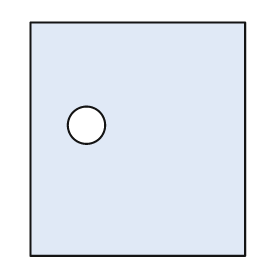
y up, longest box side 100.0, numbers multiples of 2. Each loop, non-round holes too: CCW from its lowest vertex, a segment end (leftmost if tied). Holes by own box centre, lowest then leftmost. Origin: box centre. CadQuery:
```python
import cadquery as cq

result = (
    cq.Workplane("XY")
    .moveTo(-46.0, -50.0)
    .lineTo(46.0, -50.0)
    .lineTo(46.0, 50.0)
    .lineTo(-46.0, 50.0)
    .close()
    .moveTo(-22.0, 6.0)
    .circle(8.0)
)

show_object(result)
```